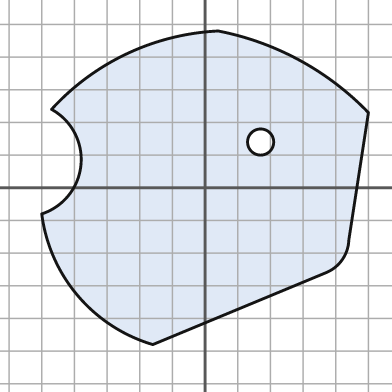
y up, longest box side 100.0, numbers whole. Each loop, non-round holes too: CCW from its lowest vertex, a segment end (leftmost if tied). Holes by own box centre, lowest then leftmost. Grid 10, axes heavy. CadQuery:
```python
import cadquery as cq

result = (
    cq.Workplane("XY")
    .moveTo(-16.0, -48.0)
    .lineTo(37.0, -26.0)
    .threePointArc((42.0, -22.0), (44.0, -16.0))
    .lineTo(50.0, 23.0)
    .threePointArc((29.0, 39.0), (4.0, 48.0))
    .threePointArc((-24.0, 41.0), (-47.0, 24.0))
    .threePointArc((-38.0, 7.0), (-50.0, -8.0))
    .threePointArc((-39.0, -33.0), (-16.0, -48.0))
    .close()
    .moveTo(17.0, 14.0)
    .circle(4.0)
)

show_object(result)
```